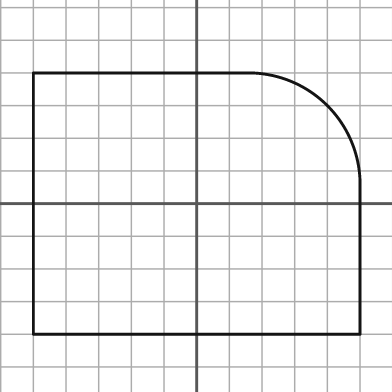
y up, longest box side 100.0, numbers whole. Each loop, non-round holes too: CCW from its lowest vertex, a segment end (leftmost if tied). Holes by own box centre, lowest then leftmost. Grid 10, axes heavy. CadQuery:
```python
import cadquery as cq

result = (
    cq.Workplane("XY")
    .moveTo(-50.0, -40.0)
    .lineTo(50.0, -40.0)
    .lineTo(50.0, 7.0)
    .threePointArc((40.0, 30.0), (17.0, 40.0))
    .lineTo(-50.0, 40.0)
    .close()
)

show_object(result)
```